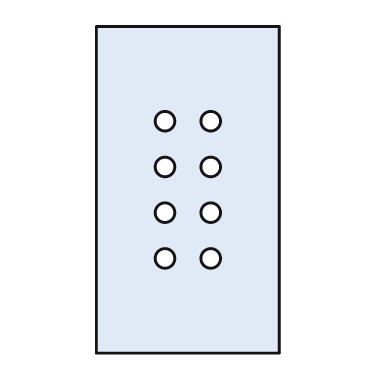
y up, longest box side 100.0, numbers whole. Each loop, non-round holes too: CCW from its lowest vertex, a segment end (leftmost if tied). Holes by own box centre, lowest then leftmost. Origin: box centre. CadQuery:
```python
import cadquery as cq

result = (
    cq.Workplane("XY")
    .moveTo(-28.0, -50.0)
    .lineTo(28.0, -50.0)
    .lineTo(28.0, 50.0)
    .lineTo(-28.0, 50.0)
    .close()
    .moveTo(-7.0, -21.0)
    .circle(3.0)
    .moveTo(7.0, -21.0)
    .circle(3.0)
    .moveTo(-7.0, -7.0)
    .circle(3.0)
    .moveTo(7.0, -7.0)
    .circle(3.0)
    .moveTo(-7.0, 7.0)
    .circle(3.0)
    .moveTo(7.0, 7.0)
    .circle(3.0)
    .moveTo(-7.0, 21.0)
    .circle(3.0)
    .moveTo(7.0, 21.0)
    .circle(3.0)
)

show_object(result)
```